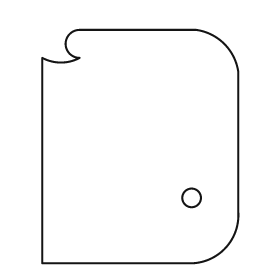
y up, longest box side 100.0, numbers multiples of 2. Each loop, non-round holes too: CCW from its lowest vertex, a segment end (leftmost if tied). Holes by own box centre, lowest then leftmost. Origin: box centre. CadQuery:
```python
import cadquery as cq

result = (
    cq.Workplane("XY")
    .moveTo(-42.0, -50.0)
    .lineTo(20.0, -50.0)
    .threePointArc((36.0, -44.0), (42.0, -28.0))
    .lineTo(42.0, 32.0)
    .threePointArc((36.0, 44.0), (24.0, 50.0))
    .lineTo(-26.0, 50.0)
    .threePointArc((-32.0, 44.0), (-26.0, 38.0))
    .threePointArc((-34.0, 36.0), (-42.0, 38.0))
    .close()
    .moveTo(22.0, -22.0)
    .circle(4.0)
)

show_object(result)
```